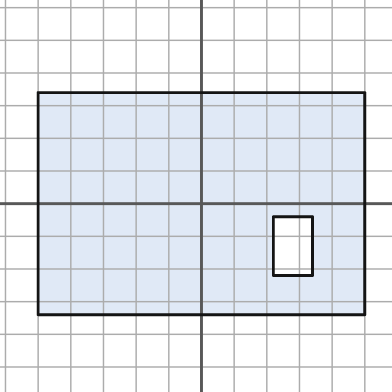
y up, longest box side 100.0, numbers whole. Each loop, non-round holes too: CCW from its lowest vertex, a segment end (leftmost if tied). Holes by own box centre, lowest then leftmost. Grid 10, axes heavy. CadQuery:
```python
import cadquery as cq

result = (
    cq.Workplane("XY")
    .moveTo(-50.0, -34.0)
    .lineTo(50.0, -34.0)
    .lineTo(50.0, 34.0)
    .lineTo(-50.0, 34.0)
    .close()
    .moveTo(22.0, -22.0)
    .lineTo(34.0, -22.0)
    .lineTo(34.0, -4.0)
    .lineTo(22.0, -4.0)
    .close()
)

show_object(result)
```